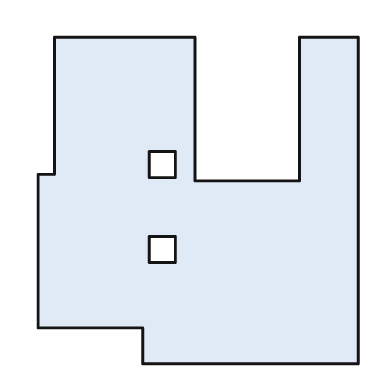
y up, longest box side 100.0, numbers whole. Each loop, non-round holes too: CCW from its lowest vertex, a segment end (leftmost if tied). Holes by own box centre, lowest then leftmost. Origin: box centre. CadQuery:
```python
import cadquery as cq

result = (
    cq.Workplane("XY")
    .moveTo(-17.0, -50.0)
    .lineTo(49.0, -50.0)
    .lineTo(49.0, 50.0)
    .lineTo(31.0, 50.0)
    .lineTo(31.0, 6.0)
    .lineTo(-1.0, 6.0)
    .lineTo(-1.0, 50.0)
    .lineTo(-44.0, 50.0)
    .lineTo(-44.0, 8.0)
    .lineTo(-49.0, 8.0)
    .lineTo(-49.0, -39.0)
    .lineTo(-17.0, -39.0)
    .close()
    .moveTo(-15.0, -19.0)
    .lineTo(-7.0, -19.0)
    .lineTo(-7.0, -11.0)
    .lineTo(-15.0, -11.0)
    .close()
    .moveTo(-15.0, 7.0)
    .lineTo(-7.0, 7.0)
    .lineTo(-7.0, 15.0)
    .lineTo(-15.0, 15.0)
    .close()
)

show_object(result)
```